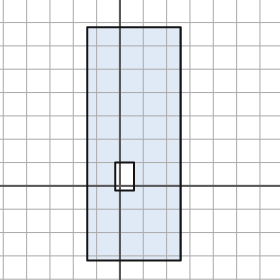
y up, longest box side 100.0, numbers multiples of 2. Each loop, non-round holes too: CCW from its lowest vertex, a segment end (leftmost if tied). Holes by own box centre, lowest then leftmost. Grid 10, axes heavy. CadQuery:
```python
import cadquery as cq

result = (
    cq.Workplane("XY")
    .moveTo(-14.0, -32.0)
    .lineTo(26.0, -32.0)
    .lineTo(26.0, 68.0)
    .lineTo(-14.0, 68.0)
    .close()
    .moveTo(-2.0, -2.0)
    .lineTo(6.0, -2.0)
    .lineTo(6.0, 10.0)
    .lineTo(-2.0, 10.0)
    .close()
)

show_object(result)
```